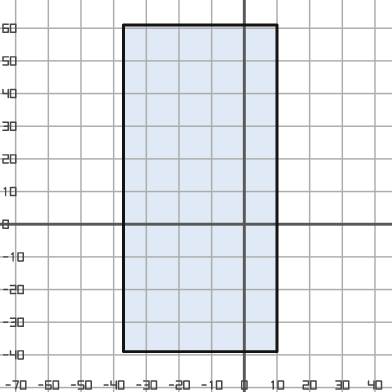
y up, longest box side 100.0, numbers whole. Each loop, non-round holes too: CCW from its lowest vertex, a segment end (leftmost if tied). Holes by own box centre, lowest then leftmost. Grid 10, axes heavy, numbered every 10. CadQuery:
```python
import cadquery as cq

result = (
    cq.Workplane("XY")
    .moveTo(-37.0, -39.0)
    .lineTo(10.0, -39.0)
    .lineTo(10.0, 61.0)
    .lineTo(-37.0, 61.0)
    .close()
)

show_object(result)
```